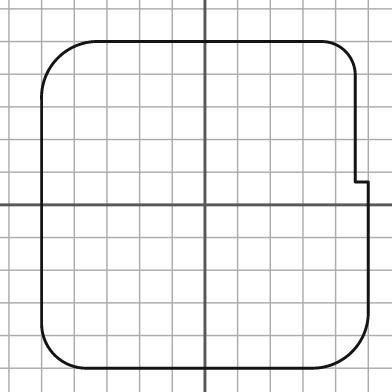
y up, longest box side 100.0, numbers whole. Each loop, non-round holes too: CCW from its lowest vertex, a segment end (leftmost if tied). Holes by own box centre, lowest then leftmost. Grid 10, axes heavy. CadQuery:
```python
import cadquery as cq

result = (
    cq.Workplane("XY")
    .moveTo(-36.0, -50.0)
    .lineTo(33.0, -50.0)
    .threePointArc((45.0, -45.0), (50.0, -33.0))
    .lineTo(50.0, 7.0)
    .lineTo(46.0, 7.0)
    .lineTo(46.0, 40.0)
    .threePointArc((43.0, 47.0), (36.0, 50.0))
    .lineTo(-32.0, 50.0)
    .threePointArc((-45.0, 45.0), (-50.0, 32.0))
    .lineTo(-50.0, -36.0)
    .threePointArc((-46.0, -46.0), (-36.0, -50.0))
    .close()
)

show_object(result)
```